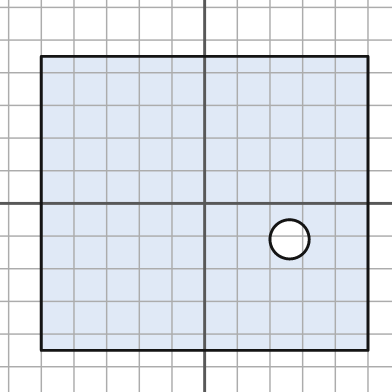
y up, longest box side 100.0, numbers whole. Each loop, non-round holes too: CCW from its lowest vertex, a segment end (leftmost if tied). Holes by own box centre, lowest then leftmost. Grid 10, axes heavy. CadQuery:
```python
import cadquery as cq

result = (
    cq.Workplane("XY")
    .moveTo(-50.0, -45.0)
    .lineTo(50.0, -45.0)
    .lineTo(50.0, 45.0)
    .lineTo(-50.0, 45.0)
    .close()
    .moveTo(26.0, -11.0)
    .circle(6.0)
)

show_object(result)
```